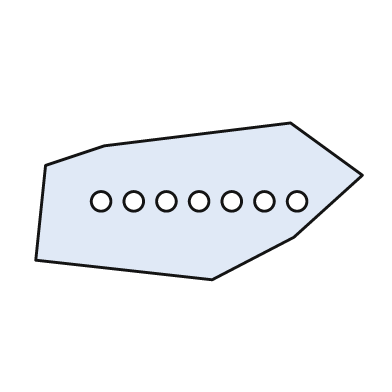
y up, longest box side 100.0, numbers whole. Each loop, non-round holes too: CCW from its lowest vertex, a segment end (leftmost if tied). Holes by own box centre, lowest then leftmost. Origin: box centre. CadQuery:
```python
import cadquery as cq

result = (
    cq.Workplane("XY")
    .moveTo(4.0, -24.0)
    .lineTo(29.0, -11.0)
    .lineTo(50.0, 8.0)
    .lineTo(28.0, 24.0)
    .lineTo(-29.0, 17.0)
    .lineTo(-47.0, 11.0)
    .lineTo(-50.0, -18.0)
    .close()
    .moveTo(-30.0, 0.0)
    .circle(3.0)
    .moveTo(-20.0, 0.0)
    .circle(3.0)
    .moveTo(-10.0, 0.0)
    .circle(3.0)
    .moveTo(0.0, 0.0)
    .circle(3.0)
    .moveTo(10.0, 0.0)
    .circle(3.0)
    .moveTo(20.0, 0.0)
    .circle(3.0)
    .moveTo(30.0, 0.0)
    .circle(3.0)
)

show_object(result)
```